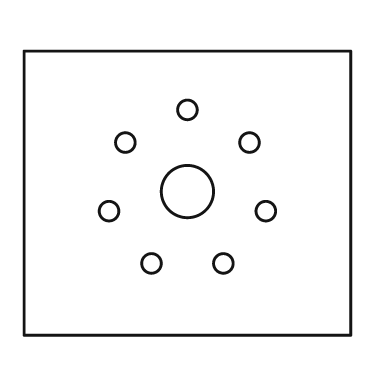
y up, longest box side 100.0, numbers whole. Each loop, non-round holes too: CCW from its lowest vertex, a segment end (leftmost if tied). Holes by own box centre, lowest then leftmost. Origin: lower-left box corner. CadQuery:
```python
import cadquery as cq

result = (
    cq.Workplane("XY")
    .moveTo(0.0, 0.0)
    .lineTo(100.0, 0.0)
    .lineTo(100.0, 87.0)
    .lineTo(0.0, 87.0)
    .close()
    .moveTo(39.0, 22.0)
    .circle(3.0)
    .moveTo(61.0, 22.0)
    .circle(3.0)
    .moveTo(26.0, 38.0)
    .circle(3.0)
    .moveTo(74.0, 38.0)
    .circle(3.0)
    .moveTo(50.0, 44.0)
    .circle(8.0)
    .moveTo(31.0, 59.0)
    .circle(3.0)
    .moveTo(69.0, 59.0)
    .circle(3.0)
    .moveTo(50.0, 69.0)
    .circle(3.0)
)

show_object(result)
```